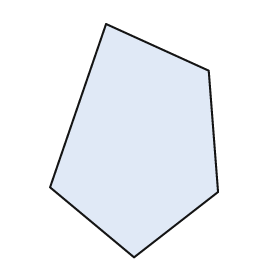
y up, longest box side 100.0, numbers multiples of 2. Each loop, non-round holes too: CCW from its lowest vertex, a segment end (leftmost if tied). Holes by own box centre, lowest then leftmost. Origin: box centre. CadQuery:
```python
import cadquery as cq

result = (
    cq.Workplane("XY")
    .moveTo(0.0, -50.0)
    .lineTo(36.0, -22.0)
    .lineTo(32.0, 30.0)
    .lineTo(-12.0, 50.0)
    .lineTo(-36.0, -20.0)
    .close()
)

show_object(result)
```